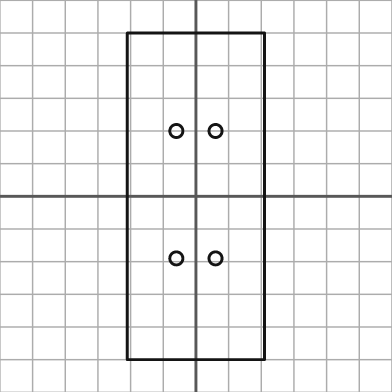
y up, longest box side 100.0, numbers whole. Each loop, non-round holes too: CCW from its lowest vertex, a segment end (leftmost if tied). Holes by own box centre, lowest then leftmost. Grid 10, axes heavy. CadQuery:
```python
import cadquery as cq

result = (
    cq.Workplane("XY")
    .moveTo(-21.0, -50.0)
    .lineTo(21.0, -50.0)
    .lineTo(21.0, 50.0)
    .lineTo(-21.0, 50.0)
    .close()
    .moveTo(-6.0, -19.0)
    .circle(2.0)
    .moveTo(6.0, -19.0)
    .circle(2.0)
    .moveTo(-6.0, 20.0)
    .circle(2.0)
    .moveTo(6.0, 20.0)
    .circle(2.0)
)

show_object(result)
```